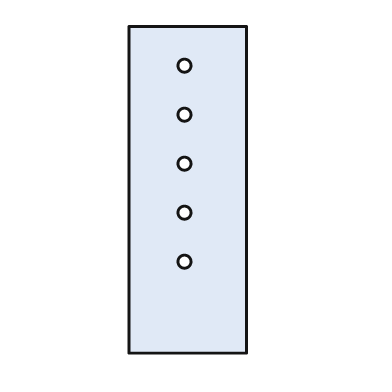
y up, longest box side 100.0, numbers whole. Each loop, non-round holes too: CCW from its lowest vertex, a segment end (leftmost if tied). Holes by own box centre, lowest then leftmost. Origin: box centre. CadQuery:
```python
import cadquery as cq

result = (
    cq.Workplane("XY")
    .moveTo(-18.0, -50.0)
    .lineTo(18.0, -50.0)
    .lineTo(18.0, 50.0)
    .lineTo(-18.0, 50.0)
    .close()
    .moveTo(-1.0, -22.0)
    .circle(2.0)
    .moveTo(-1.0, -7.0)
    .circle(2.0)
    .moveTo(-1.0, 8.0)
    .circle(2.0)
    .moveTo(-1.0, 23.0)
    .circle(2.0)
    .moveTo(-1.0, 38.0)
    .circle(2.0)
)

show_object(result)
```